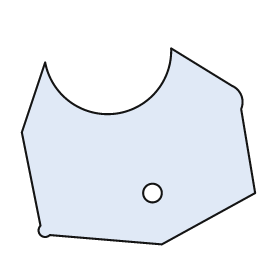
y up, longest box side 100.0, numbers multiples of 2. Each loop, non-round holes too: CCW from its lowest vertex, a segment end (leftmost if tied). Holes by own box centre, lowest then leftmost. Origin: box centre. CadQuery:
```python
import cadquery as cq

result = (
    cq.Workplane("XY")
    .moveTo(10.0, -42.0)
    .lineTo(50.0, -20.0)
    .lineTo(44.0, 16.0)
    .threePointArc((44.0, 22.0), (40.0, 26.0))
    .lineTo(14.0, 42.0)
    .threePointArc((-10.0, 14.0), (-40.0, 36.0))
    .lineTo(-50.0, 6.0)
    .lineTo(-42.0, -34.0)
    .threePointArc((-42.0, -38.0), (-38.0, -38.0))
    .close()
    .moveTo(6.0, -20.0)
    .circle(4.0)
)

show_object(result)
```